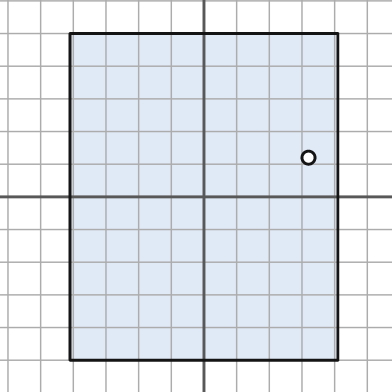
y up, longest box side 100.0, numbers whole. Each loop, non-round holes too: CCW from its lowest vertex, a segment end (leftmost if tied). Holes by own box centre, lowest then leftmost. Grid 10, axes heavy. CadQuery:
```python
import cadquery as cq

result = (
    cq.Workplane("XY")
    .moveTo(-41.0, -50.0)
    .lineTo(41.0, -50.0)
    .lineTo(41.0, 50.0)
    .lineTo(-41.0, 50.0)
    .close()
    .moveTo(32.0, 12.0)
    .circle(2.0)
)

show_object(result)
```